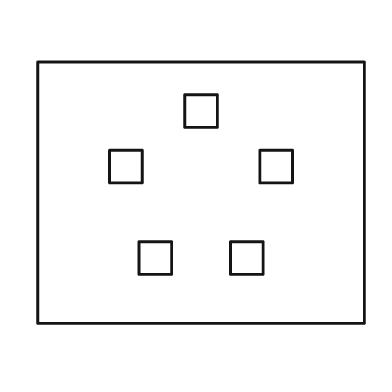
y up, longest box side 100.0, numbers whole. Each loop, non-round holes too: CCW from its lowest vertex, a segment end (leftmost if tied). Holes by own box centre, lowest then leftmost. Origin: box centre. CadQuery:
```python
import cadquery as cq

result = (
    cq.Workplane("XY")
    .moveTo(-50.0, -40.0)
    .lineTo(50.0, -40.0)
    .lineTo(50.0, 40.0)
    .lineTo(-50.0, 40.0)
    .close()
    .moveTo(-19.0, -25.0)
    .lineTo(-9.0, -25.0)
    .lineTo(-9.0, -15.0)
    .lineTo(-19.0, -15.0)
    .close()
    .moveTo(9.0, -25.0)
    .lineTo(19.0, -25.0)
    .lineTo(19.0, -15.0)
    .lineTo(9.0, -15.0)
    .close()
    .moveTo(-28.0, 3.0)
    .lineTo(-18.0, 3.0)
    .lineTo(-18.0, 13.0)
    .lineTo(-28.0, 13.0)
    .close()
    .moveTo(18.0, 3.0)
    .lineTo(28.0, 3.0)
    .lineTo(28.0, 13.0)
    .lineTo(18.0, 13.0)
    .close()
    .moveTo(-5.0, 20.0)
    .lineTo(5.0, 20.0)
    .lineTo(5.0, 30.0)
    .lineTo(-5.0, 30.0)
    .close()
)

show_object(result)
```